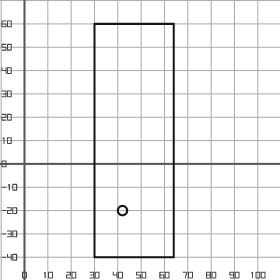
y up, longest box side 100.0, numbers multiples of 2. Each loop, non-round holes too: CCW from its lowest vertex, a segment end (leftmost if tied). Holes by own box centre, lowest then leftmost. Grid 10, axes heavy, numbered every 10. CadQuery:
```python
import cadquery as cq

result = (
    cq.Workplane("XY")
    .moveTo(30.0, -40.0)
    .lineTo(64.0, -40.0)
    .lineTo(64.0, 60.0)
    .lineTo(30.0, 60.0)
    .close()
    .moveTo(42.0, -20.0)
    .circle(2.0)
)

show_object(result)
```